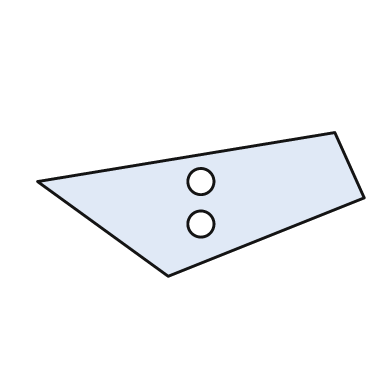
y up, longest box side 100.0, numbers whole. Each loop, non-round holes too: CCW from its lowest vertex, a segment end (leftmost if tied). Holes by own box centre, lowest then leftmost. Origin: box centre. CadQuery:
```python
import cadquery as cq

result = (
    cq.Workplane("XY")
    .moveTo(-10.0, -22.0)
    .lineTo(50.0, 2.0)
    .lineTo(41.0, 22.0)
    .lineTo(-50.0, 7.0)
    .close()
    .moveTo(0.0, -6.0)
    .circle(4.0)
    .moveTo(0.0, 7.0)
    .circle(4.0)
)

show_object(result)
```